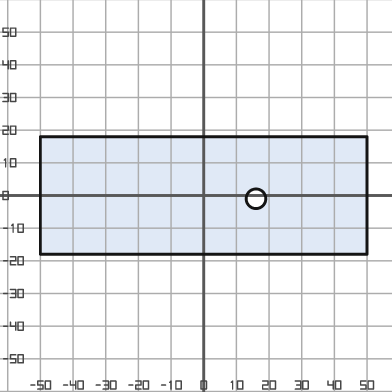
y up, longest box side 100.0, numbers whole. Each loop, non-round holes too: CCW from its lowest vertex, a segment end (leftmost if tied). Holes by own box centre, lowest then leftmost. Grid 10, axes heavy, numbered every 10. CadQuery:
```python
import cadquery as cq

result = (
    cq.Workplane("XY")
    .moveTo(-50.0, -18.0)
    .lineTo(50.0, -18.0)
    .lineTo(50.0, 18.0)
    .lineTo(-50.0, 18.0)
    .close()
    .moveTo(16.0, -1.0)
    .circle(3.0)
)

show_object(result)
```